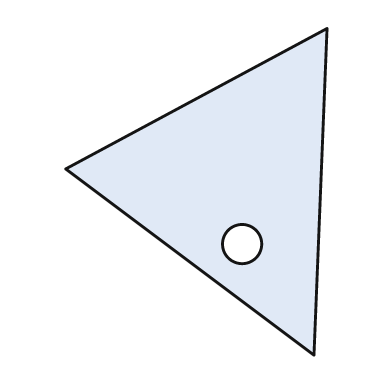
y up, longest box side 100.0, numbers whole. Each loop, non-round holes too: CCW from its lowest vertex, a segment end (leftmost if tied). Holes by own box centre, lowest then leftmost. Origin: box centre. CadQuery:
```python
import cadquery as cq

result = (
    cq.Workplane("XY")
    .moveTo(36.0, -50.0)
    .lineTo(40.0, 50.0)
    .lineTo(-40.0, 7.0)
    .close()
    .moveTo(14.0, -16.0)
    .circle(6.0)
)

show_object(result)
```